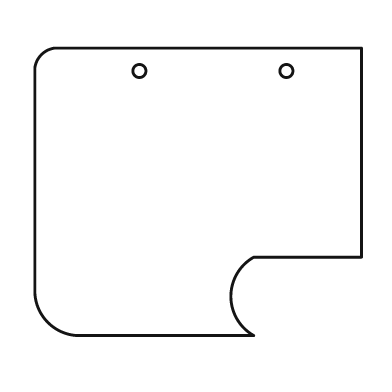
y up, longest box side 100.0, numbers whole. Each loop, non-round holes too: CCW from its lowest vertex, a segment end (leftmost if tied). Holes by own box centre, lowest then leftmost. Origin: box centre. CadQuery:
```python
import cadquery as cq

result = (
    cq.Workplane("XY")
    .moveTo(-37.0, -44.0)
    .lineTo(17.0, -44.0)
    .threePointArc((10.0, -32.0), (17.0, -20.0))
    .lineTo(50.0, -20.0)
    .lineTo(50.0, 44.0)
    .lineTo(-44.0, 44.0)
    .threePointArc((-48.0, 42.0), (-50.0, 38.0))
    .lineTo(-50.0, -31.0)
    .threePointArc((-46.0, -40.0), (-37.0, -44.0))
    .close()
    .moveTo(-18.0, 37.0)
    .circle(2.0)
    .moveTo(27.0, 37.0)
    .circle(2.0)
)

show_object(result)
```